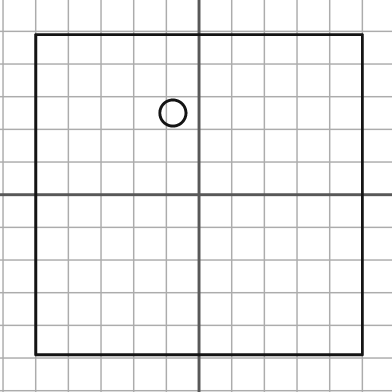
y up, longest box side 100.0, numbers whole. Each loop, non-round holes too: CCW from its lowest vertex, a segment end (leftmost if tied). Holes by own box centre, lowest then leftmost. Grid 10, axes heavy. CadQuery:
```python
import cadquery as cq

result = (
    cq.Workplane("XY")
    .moveTo(-50.0, -49.0)
    .lineTo(50.0, -49.0)
    .lineTo(50.0, 49.0)
    .lineTo(-50.0, 49.0)
    .close()
    .moveTo(-8.0, 25.0)
    .circle(4.0)
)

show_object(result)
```